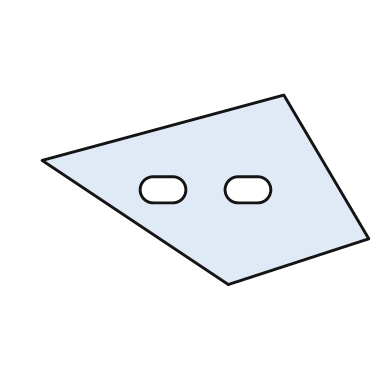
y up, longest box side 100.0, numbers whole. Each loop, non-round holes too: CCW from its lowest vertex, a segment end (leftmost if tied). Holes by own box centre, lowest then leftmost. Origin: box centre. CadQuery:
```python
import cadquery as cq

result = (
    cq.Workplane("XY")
    .moveTo(7.0, -29.0)
    .lineTo(50.0, -15.0)
    .lineTo(24.0, 29.0)
    .lineTo(-50.0, 9.0)
    .close()
    .moveTo(-16.0, -4.0)
    .lineTo(-10.0, -4.0)
    .threePointArc((-6.0, 0.0), (-10.0, 4.0))
    .lineTo(-16.0, 4.0)
    .threePointArc((-20.0, 0.0), (-16.0, -4.0))
    .close()
    .moveTo(10.0, -4.0)
    .lineTo(16.0, -4.0)
    .threePointArc((20.0, 0.0), (16.0, 4.0))
    .lineTo(10.0, 4.0)
    .threePointArc((6.0, 0.0), (10.0, -4.0))
    .close()
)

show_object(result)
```